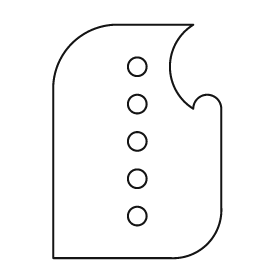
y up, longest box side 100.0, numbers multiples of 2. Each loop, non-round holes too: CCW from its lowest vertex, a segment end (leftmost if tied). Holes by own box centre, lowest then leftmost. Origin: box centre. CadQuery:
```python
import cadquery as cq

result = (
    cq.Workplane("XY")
    .moveTo(-36.0, -50.0)
    .lineTo(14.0, -50.0)
    .threePointArc((30.0, -44.0), (36.0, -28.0))
    .lineTo(36.0, 14.0)
    .threePointArc((30.0, 20.0), (24.0, 14.0))
    .threePointArc((14.0, 32.0), (24.0, 50.0))
    .lineTo(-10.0, 50.0)
    .threePointArc((-28.0, 42.0), (-36.0, 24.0))
    .close()
    .moveTo(0.0, -32.0)
    .circle(4.0)
    .moveTo(0.0, -16.0)
    .circle(4.0)
    .moveTo(0.0, 0.0)
    .circle(4.0)
    .moveTo(0.0, 16.0)
    .circle(4.0)
    .moveTo(0.0, 32.0)
    .circle(4.0)
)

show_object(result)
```